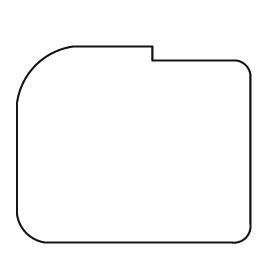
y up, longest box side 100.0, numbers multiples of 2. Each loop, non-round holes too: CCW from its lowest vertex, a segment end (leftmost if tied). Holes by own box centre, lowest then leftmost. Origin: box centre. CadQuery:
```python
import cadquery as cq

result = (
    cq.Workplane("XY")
    .moveTo(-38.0, -42.0)
    .lineTo(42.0, -42.0)
    .threePointArc((48.0, -40.0), (50.0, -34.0))
    .lineTo(50.0, 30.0)
    .threePointArc((48.0, 34.0), (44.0, 36.0))
    .lineTo(8.0, 36.0)
    .lineTo(8.0, 42.0)
    .lineTo(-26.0, 42.0)
    .threePointArc((-42.0, 34.0), (-50.0, 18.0))
    .lineTo(-50.0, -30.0)
    .threePointArc((-46.0, -38.0), (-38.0, -42.0))
    .close()
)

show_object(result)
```